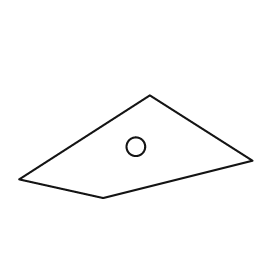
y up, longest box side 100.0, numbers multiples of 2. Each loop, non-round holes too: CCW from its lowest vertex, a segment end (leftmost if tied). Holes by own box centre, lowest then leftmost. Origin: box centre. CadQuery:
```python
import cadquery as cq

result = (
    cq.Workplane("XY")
    .moveTo(-14.0, -22.0)
    .lineTo(50.0, -6.0)
    .lineTo(6.0, 22.0)
    .lineTo(-50.0, -14.0)
    .close()
    .moveTo(0.0, 0.0)
    .circle(4.0)
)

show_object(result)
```